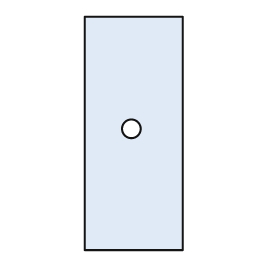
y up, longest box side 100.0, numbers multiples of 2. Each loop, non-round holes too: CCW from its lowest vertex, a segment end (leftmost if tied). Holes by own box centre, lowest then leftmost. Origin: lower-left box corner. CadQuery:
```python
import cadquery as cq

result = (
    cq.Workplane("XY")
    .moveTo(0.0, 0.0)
    .lineTo(42.0, 0.0)
    .lineTo(42.0, 100.0)
    .lineTo(0.0, 100.0)
    .close()
    .moveTo(20.0, 52.0)
    .circle(4.0)
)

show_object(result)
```